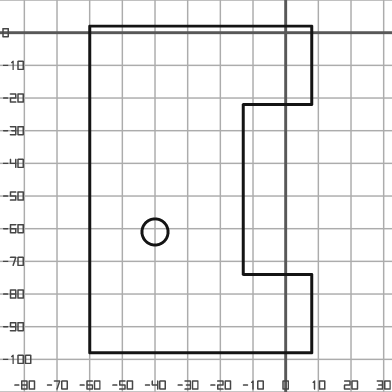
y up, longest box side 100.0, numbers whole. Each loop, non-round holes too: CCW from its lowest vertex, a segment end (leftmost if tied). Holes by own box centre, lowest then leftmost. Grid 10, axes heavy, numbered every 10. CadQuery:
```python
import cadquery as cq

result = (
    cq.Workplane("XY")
    .moveTo(-60.0, -98.0)
    .lineTo(8.0, -98.0)
    .lineTo(8.0, -74.0)
    .lineTo(-13.0, -74.0)
    .lineTo(-13.0, -22.0)
    .lineTo(8.0, -22.0)
    .lineTo(8.0, 2.0)
    .lineTo(-60.0, 2.0)
    .close()
    .moveTo(-40.0, -61.0)
    .circle(4.0)
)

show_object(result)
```